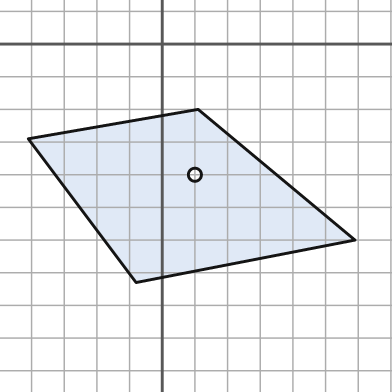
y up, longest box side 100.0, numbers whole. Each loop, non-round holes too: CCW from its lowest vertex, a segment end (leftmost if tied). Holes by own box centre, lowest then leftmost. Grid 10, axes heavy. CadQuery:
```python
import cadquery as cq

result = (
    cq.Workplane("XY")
    .moveTo(-8.0, -73.0)
    .lineTo(59.0, -60.0)
    .lineTo(11.0, -20.0)
    .lineTo(-41.0, -29.0)
    .close()
    .moveTo(10.0, -40.0)
    .circle(2.0)
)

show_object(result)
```